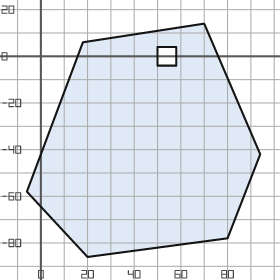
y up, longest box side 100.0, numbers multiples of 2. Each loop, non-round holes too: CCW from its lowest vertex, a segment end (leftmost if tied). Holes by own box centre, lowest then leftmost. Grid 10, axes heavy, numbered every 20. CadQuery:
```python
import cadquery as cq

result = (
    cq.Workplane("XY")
    .moveTo(20.0, -86.0)
    .lineTo(80.0, -78.0)
    .lineTo(94.0, -42.0)
    .lineTo(70.0, 14.0)
    .lineTo(18.0, 6.0)
    .lineTo(-6.0, -58.0)
    .close()
    .moveTo(50.0, -4.0)
    .lineTo(58.0, -4.0)
    .lineTo(58.0, 4.0)
    .lineTo(50.0, 4.0)
    .close()
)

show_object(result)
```